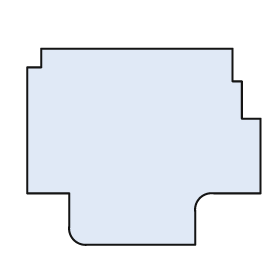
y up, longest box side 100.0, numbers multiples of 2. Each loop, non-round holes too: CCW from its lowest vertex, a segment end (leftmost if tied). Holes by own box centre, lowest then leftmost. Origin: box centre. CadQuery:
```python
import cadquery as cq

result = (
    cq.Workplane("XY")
    .moveTo(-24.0, -42.0)
    .lineTo(22.0, -42.0)
    .lineTo(22.0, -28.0)
    .threePointArc((24.0, -22.0), (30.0, -20.0))
    .lineTo(50.0, -20.0)
    .lineTo(50.0, 12.0)
    .lineTo(42.0, 12.0)
    .lineTo(42.0, 28.0)
    .lineTo(38.0, 28.0)
    .lineTo(38.0, 42.0)
    .lineTo(-44.0, 42.0)
    .lineTo(-44.0, 34.0)
    .lineTo(-50.0, 34.0)
    .lineTo(-50.0, -20.0)
    .lineTo(-32.0, -20.0)
    .lineTo(-32.0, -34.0)
    .threePointArc((-30.0, -40.0), (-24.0, -42.0))
    .close()
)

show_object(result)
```